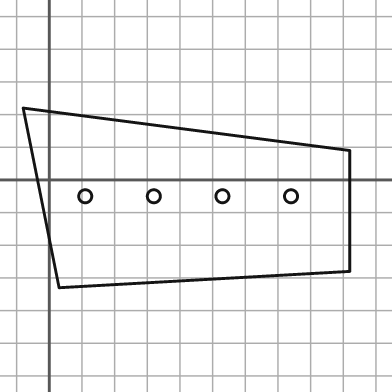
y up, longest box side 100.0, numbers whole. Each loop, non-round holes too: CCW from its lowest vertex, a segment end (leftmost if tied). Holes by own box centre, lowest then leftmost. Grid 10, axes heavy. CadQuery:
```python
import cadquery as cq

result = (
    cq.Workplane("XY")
    .moveTo(3.0, -33.0)
    .lineTo(92.0, -28.0)
    .lineTo(92.0, 9.0)
    .lineTo(-8.0, 22.0)
    .close()
    .moveTo(11.0, -5.0)
    .circle(2.0)
    .moveTo(32.0, -5.0)
    .circle(2.0)
    .moveTo(53.0, -5.0)
    .circle(2.0)
    .moveTo(74.0, -5.0)
    .circle(2.0)
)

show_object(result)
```